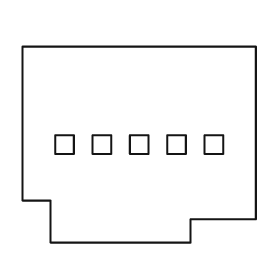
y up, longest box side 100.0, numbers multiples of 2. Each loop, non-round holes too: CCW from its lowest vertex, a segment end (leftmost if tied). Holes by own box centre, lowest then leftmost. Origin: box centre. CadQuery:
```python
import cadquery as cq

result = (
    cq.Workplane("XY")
    .moveTo(-38.0, -42.0)
    .lineTo(22.0, -42.0)
    .lineTo(22.0, -32.0)
    .lineTo(50.0, -32.0)
    .lineTo(50.0, 42.0)
    .lineTo(-50.0, 42.0)
    .lineTo(-50.0, -24.0)
    .lineTo(-38.0, -24.0)
    .close()
    .moveTo(-36.0, -4.0)
    .lineTo(-28.0, -4.0)
    .lineTo(-28.0, 4.0)
    .lineTo(-36.0, 4.0)
    .close()
    .moveTo(-20.0, -4.0)
    .lineTo(-12.0, -4.0)
    .lineTo(-12.0, 4.0)
    .lineTo(-20.0, 4.0)
    .close()
    .moveTo(-4.0, -4.0)
    .lineTo(4.0, -4.0)
    .lineTo(4.0, 4.0)
    .lineTo(-4.0, 4.0)
    .close()
    .moveTo(12.0, -4.0)
    .lineTo(20.0, -4.0)
    .lineTo(20.0, 4.0)
    .lineTo(12.0, 4.0)
    .close()
    .moveTo(28.0, -4.0)
    .lineTo(36.0, -4.0)
    .lineTo(36.0, 4.0)
    .lineTo(28.0, 4.0)
    .close()
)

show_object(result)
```